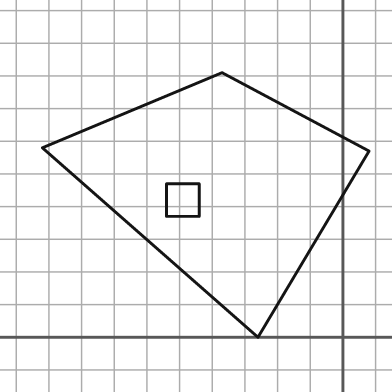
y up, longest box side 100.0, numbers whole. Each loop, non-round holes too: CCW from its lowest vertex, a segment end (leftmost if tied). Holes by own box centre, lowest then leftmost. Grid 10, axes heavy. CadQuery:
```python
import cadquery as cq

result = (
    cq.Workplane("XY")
    .moveTo(-26.0, 0.0)
    .lineTo(8.0, 57.0)
    .lineTo(-37.0, 81.0)
    .lineTo(-92.0, 58.0)
    .close()
    .moveTo(-54.0, 37.0)
    .lineTo(-44.0, 37.0)
    .lineTo(-44.0, 47.0)
    .lineTo(-54.0, 47.0)
    .close()
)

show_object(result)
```